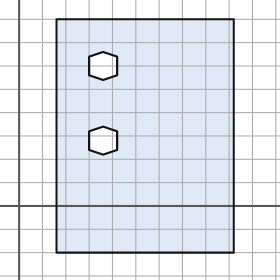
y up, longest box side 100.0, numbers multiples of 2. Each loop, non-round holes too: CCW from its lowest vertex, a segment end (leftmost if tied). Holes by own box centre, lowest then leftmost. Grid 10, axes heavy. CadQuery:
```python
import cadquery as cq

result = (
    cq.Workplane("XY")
    .moveTo(16.0, -20.0)
    .lineTo(92.0, -20.0)
    .lineTo(92.0, 80.0)
    .lineTo(16.0, 80.0)
    .close()
    .moveTo(36.0, 22.0)
    .lineTo(42.0, 24.0)
    .lineTo(42.0, 32.0)
    .lineTo(36.0, 34.0)
    .lineTo(30.0, 32.0)
    .lineTo(30.0, 24.0)
    .close()
    .moveTo(36.0, 54.0)
    .lineTo(42.0, 56.0)
    .lineTo(42.0, 64.0)
    .lineTo(36.0, 66.0)
    .lineTo(30.0, 64.0)
    .lineTo(30.0, 56.0)
    .close()
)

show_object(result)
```